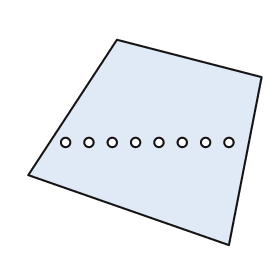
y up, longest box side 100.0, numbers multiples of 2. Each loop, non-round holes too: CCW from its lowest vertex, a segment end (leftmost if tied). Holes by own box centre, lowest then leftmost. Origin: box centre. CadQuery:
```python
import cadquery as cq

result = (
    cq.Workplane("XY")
    .moveTo(36.0, -44.0)
    .lineTo(50.0, 28.0)
    .lineTo(-12.0, 44.0)
    .lineTo(-50.0, -14.0)
    .close()
    .moveTo(-34.0, 0.0)
    .circle(2.0)
    .moveTo(-24.0, 0.0)
    .circle(2.0)
    .moveTo(-14.0, 0.0)
    .circle(2.0)
    .moveTo(-4.0, 0.0)
    .circle(2.0)
    .moveTo(6.0, 0.0)
    .circle(2.0)
    .moveTo(16.0, 0.0)
    .circle(2.0)
    .moveTo(26.0, 0.0)
    .circle(2.0)
    .moveTo(36.0, 0.0)
    .circle(2.0)
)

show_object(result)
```